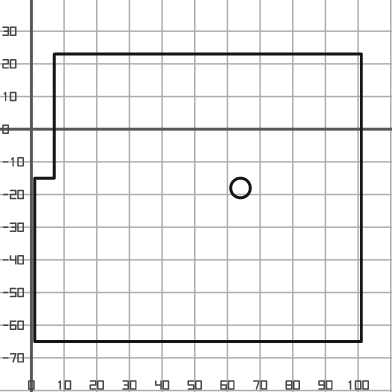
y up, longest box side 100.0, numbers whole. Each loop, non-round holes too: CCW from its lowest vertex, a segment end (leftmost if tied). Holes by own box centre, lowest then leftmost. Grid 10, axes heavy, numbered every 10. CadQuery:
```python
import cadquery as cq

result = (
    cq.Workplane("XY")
    .moveTo(1.0, -65.0)
    .lineTo(101.0, -65.0)
    .lineTo(101.0, 23.0)
    .lineTo(7.0, 23.0)
    .lineTo(7.0, -15.0)
    .lineTo(1.0, -15.0)
    .close()
    .moveTo(64.0, -18.0)
    .circle(3.0)
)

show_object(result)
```